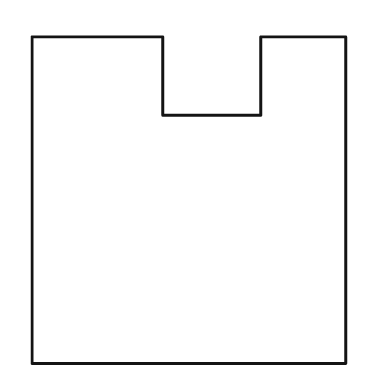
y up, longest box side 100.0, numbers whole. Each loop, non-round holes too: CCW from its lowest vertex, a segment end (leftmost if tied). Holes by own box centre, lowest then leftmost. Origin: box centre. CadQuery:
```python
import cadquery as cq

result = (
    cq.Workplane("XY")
    .moveTo(-48.0, -50.0)
    .lineTo(48.0, -50.0)
    .lineTo(48.0, 50.0)
    .lineTo(22.0, 50.0)
    .lineTo(22.0, 26.0)
    .lineTo(-8.0, 26.0)
    .lineTo(-8.0, 50.0)
    .lineTo(-48.0, 50.0)
    .close()
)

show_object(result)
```